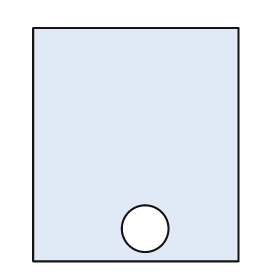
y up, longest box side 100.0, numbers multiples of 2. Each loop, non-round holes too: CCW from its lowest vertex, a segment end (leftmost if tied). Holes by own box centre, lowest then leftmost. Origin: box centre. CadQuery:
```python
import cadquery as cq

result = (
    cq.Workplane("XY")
    .moveTo(-44.0, -50.0)
    .lineTo(44.0, -50.0)
    .lineTo(44.0, 50.0)
    .lineTo(-44.0, 50.0)
    .close()
    .moveTo(4.0, -36.0)
    .circle(10.0)
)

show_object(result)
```